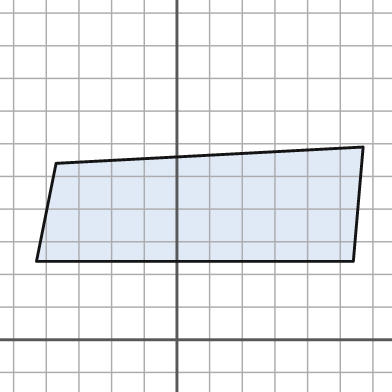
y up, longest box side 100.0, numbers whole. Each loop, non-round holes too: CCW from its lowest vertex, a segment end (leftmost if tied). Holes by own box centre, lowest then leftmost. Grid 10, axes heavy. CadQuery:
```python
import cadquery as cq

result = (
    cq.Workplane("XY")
    .moveTo(-43.0, 24.0)
    .lineTo(54.0, 24.0)
    .lineTo(57.0, 59.0)
    .lineTo(-37.0, 54.0)
    .close()
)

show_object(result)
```